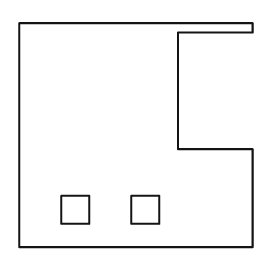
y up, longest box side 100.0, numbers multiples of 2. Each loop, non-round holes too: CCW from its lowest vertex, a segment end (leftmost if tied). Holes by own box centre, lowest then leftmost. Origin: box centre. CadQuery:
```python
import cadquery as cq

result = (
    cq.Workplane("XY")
    .moveTo(-50.0, -48.0)
    .lineTo(50.0, -48.0)
    .lineTo(50.0, -6.0)
    .lineTo(18.0, -6.0)
    .lineTo(18.0, 44.0)
    .lineTo(50.0, 44.0)
    .lineTo(50.0, 48.0)
    .lineTo(-50.0, 48.0)
    .close()
    .moveTo(-32.0, -38.0)
    .lineTo(-20.0, -38.0)
    .lineTo(-20.0, -26.0)
    .lineTo(-32.0, -26.0)
    .close()
    .moveTo(-2.0, -38.0)
    .lineTo(10.0, -38.0)
    .lineTo(10.0, -26.0)
    .lineTo(-2.0, -26.0)
    .close()
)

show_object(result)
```